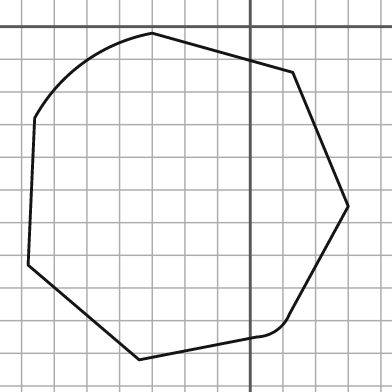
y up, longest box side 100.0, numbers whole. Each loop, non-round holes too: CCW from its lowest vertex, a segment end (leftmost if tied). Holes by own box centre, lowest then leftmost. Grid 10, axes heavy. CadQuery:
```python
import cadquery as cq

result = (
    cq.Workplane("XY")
    .moveTo(-34.0, -102.0)
    .lineTo(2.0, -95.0)
    .threePointArc((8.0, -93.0), (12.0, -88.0))
    .lineTo(30.0, -55.0)
    .lineTo(13.0, -14.0)
    .lineTo(-30.0, -2.0)
    .threePointArc((-51.0, -11.0), (-66.0, -28.0))
    .lineTo(-68.0, -73.0)
    .close()
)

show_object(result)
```